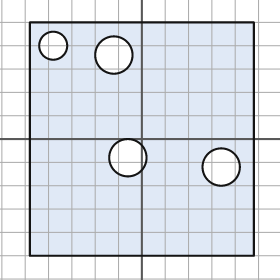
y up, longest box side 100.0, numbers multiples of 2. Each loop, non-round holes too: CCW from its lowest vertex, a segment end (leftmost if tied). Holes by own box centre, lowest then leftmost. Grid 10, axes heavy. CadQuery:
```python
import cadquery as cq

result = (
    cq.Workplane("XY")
    .moveTo(-48.0, -50.0)
    .lineTo(48.0, -50.0)
    .lineTo(48.0, 50.0)
    .lineTo(-48.0, 50.0)
    .close()
    .moveTo(34.0, -12.0)
    .circle(8.0)
    .moveTo(-6.0, -8.0)
    .circle(8.0)
    .moveTo(-12.0, 36.0)
    .circle(8.0)
    .moveTo(-38.0, 40.0)
    .circle(6.0)
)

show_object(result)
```